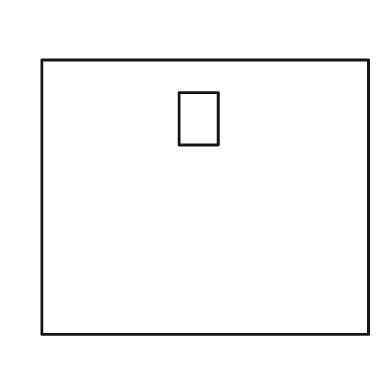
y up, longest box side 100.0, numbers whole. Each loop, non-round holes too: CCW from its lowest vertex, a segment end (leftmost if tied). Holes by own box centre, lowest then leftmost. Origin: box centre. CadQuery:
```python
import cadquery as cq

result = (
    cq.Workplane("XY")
    .moveTo(-50.0, -42.0)
    .lineTo(50.0, -42.0)
    .lineTo(50.0, 42.0)
    .lineTo(-50.0, 42.0)
    .close()
    .moveTo(-8.0, 16.0)
    .lineTo(4.0, 16.0)
    .lineTo(4.0, 32.0)
    .lineTo(-8.0, 32.0)
    .close()
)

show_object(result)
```